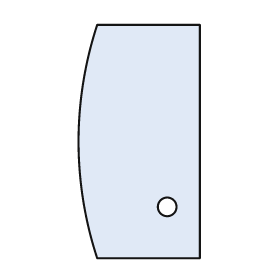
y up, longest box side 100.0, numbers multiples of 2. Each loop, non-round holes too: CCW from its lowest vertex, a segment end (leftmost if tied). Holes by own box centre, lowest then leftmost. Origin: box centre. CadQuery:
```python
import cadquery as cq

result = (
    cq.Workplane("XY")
    .moveTo(-18.0, -50.0)
    .lineTo(26.0, -50.0)
    .lineTo(26.0, 50.0)
    .lineTo(-18.0, 50.0)
    .threePointArc((-26.0, 0.0), (-18.0, -50.0))
    .close()
    .moveTo(12.0, -28.0)
    .circle(4.0)
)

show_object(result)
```